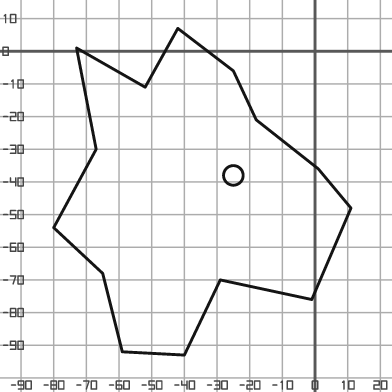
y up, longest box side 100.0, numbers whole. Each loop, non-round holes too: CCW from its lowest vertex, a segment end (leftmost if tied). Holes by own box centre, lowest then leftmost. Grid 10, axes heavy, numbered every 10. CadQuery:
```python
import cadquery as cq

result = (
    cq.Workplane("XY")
    .moveTo(-40.0, -93.0)
    .lineTo(-29.0, -70.0)
    .lineTo(-1.0, -76.0)
    .lineTo(11.0, -48.0)
    .lineTo(1.0, -36.0)
    .lineTo(-18.0, -21.0)
    .lineTo(-25.0, -6.0)
    .lineTo(-42.0, 7.0)
    .lineTo(-52.0, -11.0)
    .lineTo(-73.0, 1.0)
    .lineTo(-67.0, -30.0)
    .lineTo(-80.0, -54.0)
    .lineTo(-65.0, -68.0)
    .lineTo(-59.0, -92.0)
    .close()
    .moveTo(-25.0, -38.0)
    .circle(3.0)
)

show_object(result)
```